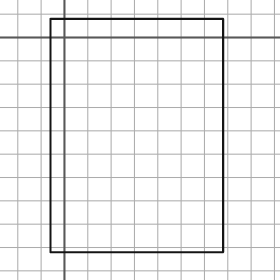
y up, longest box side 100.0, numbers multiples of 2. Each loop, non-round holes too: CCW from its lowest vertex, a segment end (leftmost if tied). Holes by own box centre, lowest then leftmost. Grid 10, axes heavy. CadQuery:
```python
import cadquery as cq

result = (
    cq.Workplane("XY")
    .moveTo(-6.0, -92.0)
    .lineTo(68.0, -92.0)
    .lineTo(68.0, 8.0)
    .lineTo(-6.0, 8.0)
    .close()
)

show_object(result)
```